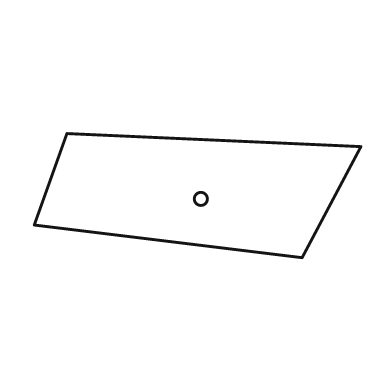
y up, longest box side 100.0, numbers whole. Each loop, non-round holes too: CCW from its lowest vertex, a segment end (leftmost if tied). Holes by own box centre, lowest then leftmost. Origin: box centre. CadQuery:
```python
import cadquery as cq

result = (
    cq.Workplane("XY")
    .moveTo(32.0, -19.0)
    .lineTo(50.0, 15.0)
    .lineTo(-40.0, 19.0)
    .lineTo(-50.0, -9.0)
    .close()
    .moveTo(1.0, -1.0)
    .circle(2.0)
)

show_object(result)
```